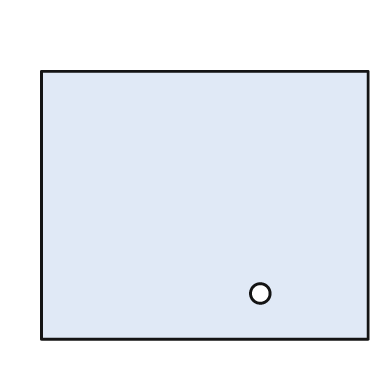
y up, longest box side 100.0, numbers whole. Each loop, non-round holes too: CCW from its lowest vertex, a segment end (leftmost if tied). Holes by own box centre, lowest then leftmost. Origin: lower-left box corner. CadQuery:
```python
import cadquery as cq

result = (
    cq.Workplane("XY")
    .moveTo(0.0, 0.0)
    .lineTo(100.0, 0.0)
    .lineTo(100.0, 82.0)
    .lineTo(0.0, 82.0)
    .close()
    .moveTo(67.0, 14.0)
    .circle(3.0)
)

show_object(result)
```